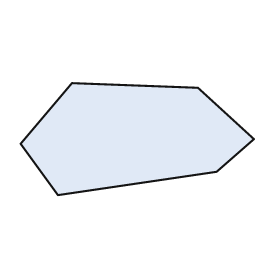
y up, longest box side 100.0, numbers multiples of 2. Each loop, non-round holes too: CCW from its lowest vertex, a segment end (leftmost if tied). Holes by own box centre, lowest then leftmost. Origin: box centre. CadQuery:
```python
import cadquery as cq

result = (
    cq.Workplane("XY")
    .moveTo(-34.0, -24.0)
    .lineTo(34.0, -14.0)
    .lineTo(50.0, 0.0)
    .lineTo(26.0, 22.0)
    .lineTo(-28.0, 24.0)
    .lineTo(-50.0, -2.0)
    .close()
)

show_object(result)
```